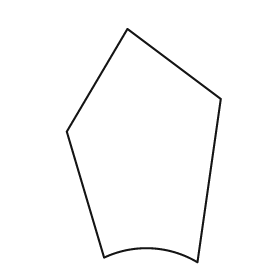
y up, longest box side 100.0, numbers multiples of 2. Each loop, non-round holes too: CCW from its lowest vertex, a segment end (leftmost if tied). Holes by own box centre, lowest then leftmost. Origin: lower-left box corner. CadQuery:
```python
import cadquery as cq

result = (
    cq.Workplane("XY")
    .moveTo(56.0, 0.0)
    .lineTo(66.0, 70.0)
    .lineTo(26.0, 100.0)
    .lineTo(0.0, 56.0)
    .lineTo(16.0, 2.0)
    .threePointArc((36.0, 6.0), (56.0, 0.0))
    .close()
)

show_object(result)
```